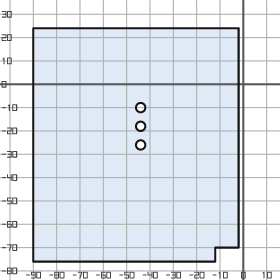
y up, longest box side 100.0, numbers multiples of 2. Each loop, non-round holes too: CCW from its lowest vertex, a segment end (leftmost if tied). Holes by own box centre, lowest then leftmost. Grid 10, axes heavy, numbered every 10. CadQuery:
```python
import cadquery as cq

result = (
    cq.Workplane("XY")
    .moveTo(-90.0, -76.0)
    .lineTo(-12.0, -76.0)
    .lineTo(-12.0, -70.0)
    .lineTo(-2.0, -70.0)
    .lineTo(-2.0, 24.0)
    .lineTo(-90.0, 24.0)
    .close()
    .moveTo(-44.0, -26.0)
    .circle(2.0)
    .moveTo(-44.0, -18.0)
    .circle(2.0)
    .moveTo(-44.0, -10.0)
    .circle(2.0)
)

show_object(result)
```